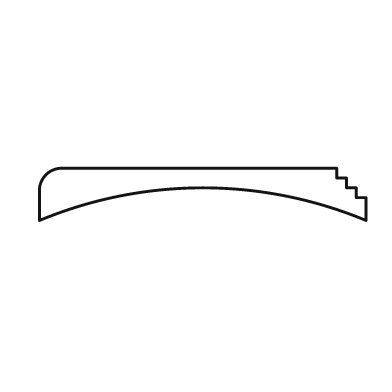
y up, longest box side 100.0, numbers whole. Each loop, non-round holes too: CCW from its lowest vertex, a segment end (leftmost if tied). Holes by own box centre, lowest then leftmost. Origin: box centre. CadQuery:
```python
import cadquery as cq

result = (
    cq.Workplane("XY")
    .moveTo(-50.0, -8.0)
    .threePointArc((0.0, 2.0), (50.0, -8.0))
    .lineTo(50.0, -1.0)
    .lineTo(47.0, -1.0)
    .lineTo(47.0, 2.0)
    .lineTo(44.0, 2.0)
    .lineTo(44.0, 5.0)
    .lineTo(41.0, 5.0)
    .lineTo(41.0, 8.0)
    .lineTo(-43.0, 8.0)
    .threePointArc((-48.0, 6.0), (-50.0, 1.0))
    .close()
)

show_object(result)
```